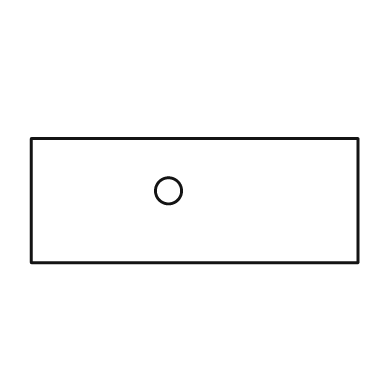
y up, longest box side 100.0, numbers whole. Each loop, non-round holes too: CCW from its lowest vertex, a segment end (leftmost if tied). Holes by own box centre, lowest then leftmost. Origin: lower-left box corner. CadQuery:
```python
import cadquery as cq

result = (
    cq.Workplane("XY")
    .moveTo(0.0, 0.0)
    .lineTo(100.0, 0.0)
    .lineTo(100.0, 38.0)
    .lineTo(0.0, 38.0)
    .close()
    .moveTo(42.0, 22.0)
    .circle(4.0)
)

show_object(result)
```